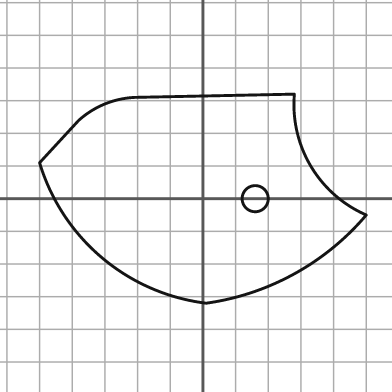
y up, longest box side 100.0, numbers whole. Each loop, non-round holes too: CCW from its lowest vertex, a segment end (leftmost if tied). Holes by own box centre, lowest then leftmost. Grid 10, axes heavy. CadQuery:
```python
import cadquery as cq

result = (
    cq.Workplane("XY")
    .moveTo(1.0, -32.0)
    .threePointArc((28.0, -23.0), (50.0, -5.0))
    .threePointArc((33.0, 10.0), (28.0, 32.0))
    .lineTo(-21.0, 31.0)
    .threePointArc((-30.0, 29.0), (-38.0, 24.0))
    .lineTo(-50.0, 11.0)
    .threePointArc((-31.0, -18.0), (1.0, -32.0))
    .close()
    .moveTo(16.0, 0.0)
    .circle(4.0)
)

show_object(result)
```